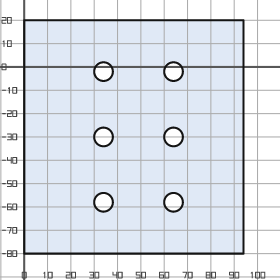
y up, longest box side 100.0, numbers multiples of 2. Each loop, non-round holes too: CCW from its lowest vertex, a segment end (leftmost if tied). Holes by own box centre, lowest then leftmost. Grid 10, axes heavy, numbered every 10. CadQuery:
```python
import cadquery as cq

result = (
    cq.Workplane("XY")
    .moveTo(0.0, -80.0)
    .lineTo(94.0, -80.0)
    .lineTo(94.0, 20.0)
    .lineTo(0.0, 20.0)
    .close()
    .moveTo(34.0, -58.0)
    .circle(4.0)
    .moveTo(64.0, -58.0)
    .circle(4.0)
    .moveTo(34.0, -30.0)
    .circle(4.0)
    .moveTo(64.0, -30.0)
    .circle(4.0)
    .moveTo(34.0, -2.0)
    .circle(4.0)
    .moveTo(64.0, -2.0)
    .circle(4.0)
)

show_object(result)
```